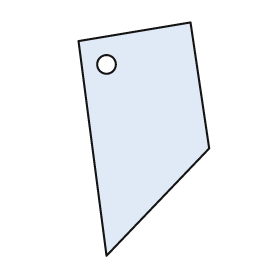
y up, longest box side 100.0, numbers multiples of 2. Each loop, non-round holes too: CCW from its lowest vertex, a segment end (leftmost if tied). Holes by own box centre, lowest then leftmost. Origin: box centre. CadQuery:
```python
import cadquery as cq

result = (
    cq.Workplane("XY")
    .moveTo(-16.0, -50.0)
    .lineTo(28.0, -4.0)
    .lineTo(20.0, 50.0)
    .lineTo(-28.0, 42.0)
    .close()
    .moveTo(-16.0, 32.0)
    .circle(4.0)
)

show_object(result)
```